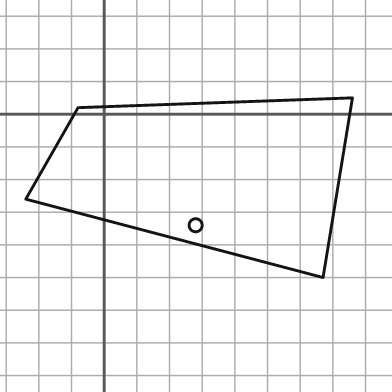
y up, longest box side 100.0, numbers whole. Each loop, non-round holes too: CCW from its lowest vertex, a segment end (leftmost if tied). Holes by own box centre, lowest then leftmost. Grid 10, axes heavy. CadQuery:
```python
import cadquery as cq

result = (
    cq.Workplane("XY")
    .moveTo(67.0, -50.0)
    .lineTo(76.0, 5.0)
    .lineTo(-8.0, 2.0)
    .lineTo(-24.0, -26.0)
    .close()
    .moveTo(28.0, -34.0)
    .circle(2.0)
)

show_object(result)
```